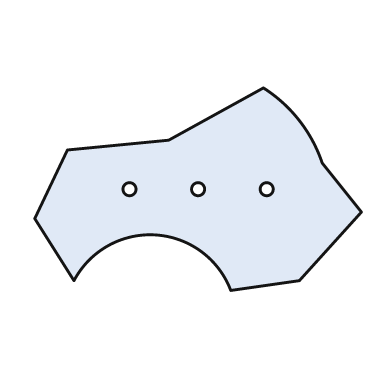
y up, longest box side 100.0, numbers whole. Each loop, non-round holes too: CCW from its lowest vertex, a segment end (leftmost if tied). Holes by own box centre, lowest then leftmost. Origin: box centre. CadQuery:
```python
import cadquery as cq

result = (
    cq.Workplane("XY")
    .moveTo(10.0, -31.0)
    .lineTo(31.0, -28.0)
    .lineTo(50.0, -7.0)
    .lineTo(38.0, 8.0)
    .threePointArc((31.0, 21.0), (20.0, 31.0))
    .lineTo(-9.0, 15.0)
    .lineTo(-40.0, 12.0)
    .lineTo(-50.0, -9.0)
    .lineTo(-38.0, -28.0)
    .threePointArc((-13.0, -14.0), (10.0, -31.0))
    .close()
    .moveTo(-21.0, 0.0)
    .circle(2.0)
    .moveTo(0.0, 0.0)
    .circle(2.0)
    .moveTo(21.0, 0.0)
    .circle(2.0)
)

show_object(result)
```